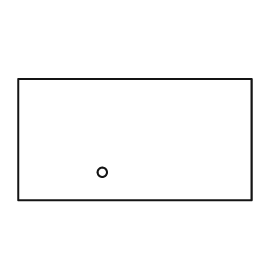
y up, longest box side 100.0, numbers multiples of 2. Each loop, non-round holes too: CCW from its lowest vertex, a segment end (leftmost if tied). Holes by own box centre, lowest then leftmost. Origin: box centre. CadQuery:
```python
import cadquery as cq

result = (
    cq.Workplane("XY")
    .moveTo(-50.0, -26.0)
    .lineTo(50.0, -26.0)
    .lineTo(50.0, 26.0)
    .lineTo(-50.0, 26.0)
    .close()
    .moveTo(-14.0, -14.0)
    .circle(2.0)
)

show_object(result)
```